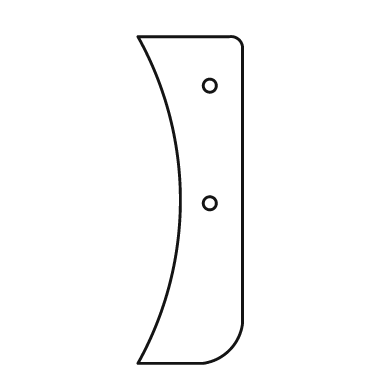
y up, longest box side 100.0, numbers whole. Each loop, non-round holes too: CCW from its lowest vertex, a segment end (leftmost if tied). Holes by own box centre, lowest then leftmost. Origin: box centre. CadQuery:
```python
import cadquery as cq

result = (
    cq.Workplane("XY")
    .moveTo(-16.0, -50.0)
    .lineTo(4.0, -50.0)
    .threePointArc((12.0, -46.0), (16.0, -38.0))
    .lineTo(16.0, 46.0)
    .threePointArc((15.0, 49.0), (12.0, 50.0))
    .lineTo(-16.0, 50.0)
    .threePointArc((-3.0, 0.0), (-16.0, -50.0))
    .close()
    .moveTo(6.0, -1.0)
    .circle(2.0)
    .moveTo(6.0, 35.0)
    .circle(2.0)
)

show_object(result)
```